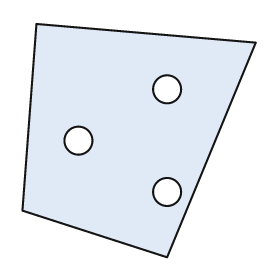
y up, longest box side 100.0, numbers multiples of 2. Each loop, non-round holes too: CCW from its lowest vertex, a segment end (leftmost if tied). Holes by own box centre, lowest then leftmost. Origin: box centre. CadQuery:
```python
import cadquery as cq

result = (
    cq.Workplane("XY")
    .moveTo(12.0, -50.0)
    .lineTo(50.0, 42.0)
    .lineTo(-44.0, 50.0)
    .lineTo(-50.0, -30.0)
    .close()
    .moveTo(12.0, -22.0)
    .circle(6.0)
    .moveTo(-26.0, 0.0)
    .circle(6.0)
    .moveTo(12.0, 22.0)
    .circle(6.0)
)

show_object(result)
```